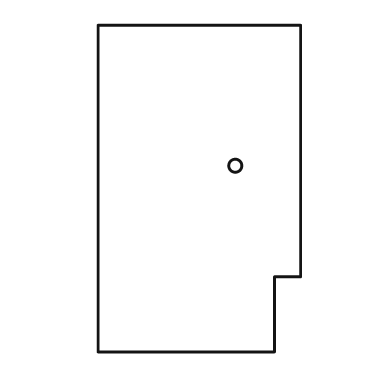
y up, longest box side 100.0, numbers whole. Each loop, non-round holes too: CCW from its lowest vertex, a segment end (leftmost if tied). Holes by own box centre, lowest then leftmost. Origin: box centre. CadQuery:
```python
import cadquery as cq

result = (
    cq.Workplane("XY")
    .moveTo(-31.0, -50.0)
    .lineTo(23.0, -50.0)
    .lineTo(23.0, -27.0)
    .lineTo(31.0, -27.0)
    .lineTo(31.0, 50.0)
    .lineTo(-31.0, 50.0)
    .close()
    .moveTo(11.0, 7.0)
    .circle(2.0)
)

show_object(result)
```